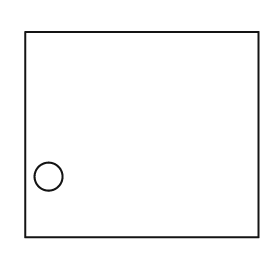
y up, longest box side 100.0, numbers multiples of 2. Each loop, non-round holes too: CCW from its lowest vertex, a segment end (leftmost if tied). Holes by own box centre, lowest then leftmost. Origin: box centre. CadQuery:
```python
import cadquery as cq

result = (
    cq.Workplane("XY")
    .moveTo(-50.0, -44.0)
    .lineTo(50.0, -44.0)
    .lineTo(50.0, 44.0)
    .lineTo(-50.0, 44.0)
    .close()
    .moveTo(-40.0, -18.0)
    .circle(6.0)
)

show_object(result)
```